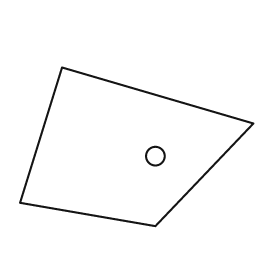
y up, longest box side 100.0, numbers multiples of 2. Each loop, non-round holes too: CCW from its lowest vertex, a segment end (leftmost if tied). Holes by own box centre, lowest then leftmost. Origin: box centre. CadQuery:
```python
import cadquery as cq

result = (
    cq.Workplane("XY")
    .moveTo(8.0, -34.0)
    .lineTo(50.0, 10.0)
    .lineTo(-32.0, 34.0)
    .lineTo(-50.0, -24.0)
    .close()
    .moveTo(8.0, -4.0)
    .circle(4.0)
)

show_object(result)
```